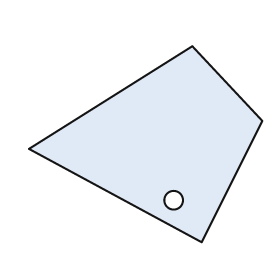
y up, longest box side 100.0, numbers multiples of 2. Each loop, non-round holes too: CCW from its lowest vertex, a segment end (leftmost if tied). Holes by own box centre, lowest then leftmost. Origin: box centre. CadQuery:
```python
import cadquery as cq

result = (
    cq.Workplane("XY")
    .moveTo(24.0, -42.0)
    .lineTo(50.0, 10.0)
    .lineTo(20.0, 42.0)
    .lineTo(-50.0, -2.0)
    .close()
    .moveTo(12.0, -24.0)
    .circle(4.0)
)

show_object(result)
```